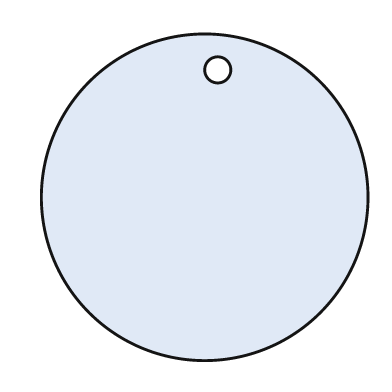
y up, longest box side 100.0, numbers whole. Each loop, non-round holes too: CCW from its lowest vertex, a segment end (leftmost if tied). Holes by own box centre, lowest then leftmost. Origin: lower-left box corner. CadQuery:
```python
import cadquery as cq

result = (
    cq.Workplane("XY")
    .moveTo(50.0, 50.0)
    .circle(50.0)
    .moveTo(54.0, 89.0)
    .circle(4.0)
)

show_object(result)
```